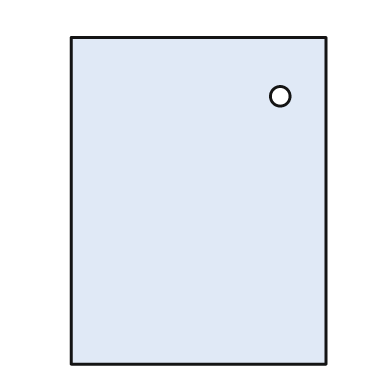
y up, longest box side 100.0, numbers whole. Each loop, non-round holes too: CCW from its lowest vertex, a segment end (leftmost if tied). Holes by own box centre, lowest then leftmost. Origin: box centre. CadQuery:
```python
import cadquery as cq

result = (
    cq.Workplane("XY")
    .moveTo(-39.0, -50.0)
    .lineTo(39.0, -50.0)
    .lineTo(39.0, 50.0)
    .lineTo(-39.0, 50.0)
    .close()
    .moveTo(25.0, 32.0)
    .circle(3.0)
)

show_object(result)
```